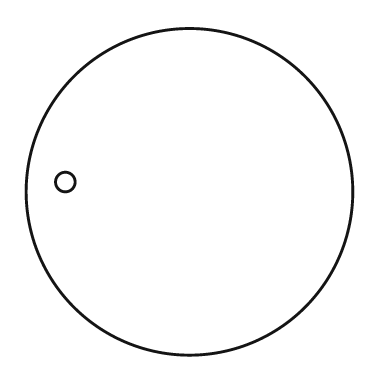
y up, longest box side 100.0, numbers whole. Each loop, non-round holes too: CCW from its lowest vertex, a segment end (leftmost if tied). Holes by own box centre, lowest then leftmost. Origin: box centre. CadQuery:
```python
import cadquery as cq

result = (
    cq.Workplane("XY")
    .moveTo(0.0, 0.0)
    .circle(50.0)
    .moveTo(-38.0, 3.0)
    .circle(3.0)
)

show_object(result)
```